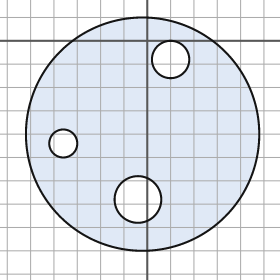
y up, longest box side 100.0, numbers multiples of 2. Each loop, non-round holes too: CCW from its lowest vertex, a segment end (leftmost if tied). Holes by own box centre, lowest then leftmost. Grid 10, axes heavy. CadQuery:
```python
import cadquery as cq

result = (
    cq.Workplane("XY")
    .moveTo(-2.0, -40.0)
    .circle(50.0)
    .moveTo(-4.0, -68.0)
    .circle(10.0)
    .moveTo(-36.0, -44.0)
    .circle(6.0)
    .moveTo(10.0, -8.0)
    .circle(8.0)
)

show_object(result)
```